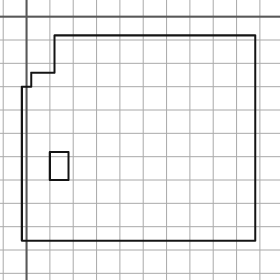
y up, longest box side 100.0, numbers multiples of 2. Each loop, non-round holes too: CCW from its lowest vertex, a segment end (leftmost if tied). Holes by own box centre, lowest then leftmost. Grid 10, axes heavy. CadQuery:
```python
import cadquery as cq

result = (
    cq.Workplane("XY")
    .moveTo(-2.0, -96.0)
    .lineTo(98.0, -96.0)
    .lineTo(98.0, -8.0)
    .lineTo(12.0, -8.0)
    .lineTo(12.0, -24.0)
    .lineTo(2.0, -24.0)
    .lineTo(2.0, -30.0)
    .lineTo(-2.0, -30.0)
    .close()
    .moveTo(10.0, -70.0)
    .lineTo(18.0, -70.0)
    .lineTo(18.0, -58.0)
    .lineTo(10.0, -58.0)
    .close()
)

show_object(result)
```